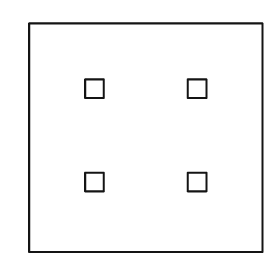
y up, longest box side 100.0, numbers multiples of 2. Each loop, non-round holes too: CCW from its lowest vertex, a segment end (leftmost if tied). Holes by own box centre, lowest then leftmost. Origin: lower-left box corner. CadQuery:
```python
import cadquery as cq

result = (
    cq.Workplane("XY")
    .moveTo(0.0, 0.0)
    .lineTo(100.0, 0.0)
    .lineTo(100.0, 98.0)
    .lineTo(0.0, 98.0)
    .close()
    .moveTo(24.0, 26.0)
    .lineTo(32.0, 26.0)
    .lineTo(32.0, 34.0)
    .lineTo(24.0, 34.0)
    .close()
    .moveTo(68.0, 26.0)
    .lineTo(76.0, 26.0)
    .lineTo(76.0, 34.0)
    .lineTo(68.0, 34.0)
    .close()
    .moveTo(24.0, 66.0)
    .lineTo(32.0, 66.0)
    .lineTo(32.0, 74.0)
    .lineTo(24.0, 74.0)
    .close()
    .moveTo(68.0, 66.0)
    .lineTo(76.0, 66.0)
    .lineTo(76.0, 74.0)
    .lineTo(68.0, 74.0)
    .close()
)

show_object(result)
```